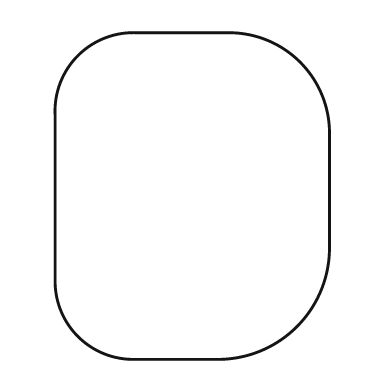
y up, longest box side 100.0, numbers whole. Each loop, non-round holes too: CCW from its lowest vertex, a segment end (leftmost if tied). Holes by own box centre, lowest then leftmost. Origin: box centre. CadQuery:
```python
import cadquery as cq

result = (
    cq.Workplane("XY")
    .moveTo(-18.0, -50.0)
    .lineTo(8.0, -50.0)
    .threePointArc((32.0, -40.0), (42.0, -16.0))
    .lineTo(42.0, 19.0)
    .threePointArc((33.0, 41.0), (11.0, 50.0))
    .lineTo(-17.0, 50.0)
    .threePointArc((-35.0, 43.0), (-42.0, 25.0))
    .lineTo(-42.0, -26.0)
    .threePointArc((-35.0, -43.0), (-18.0, -50.0))
    .close()
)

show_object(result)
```